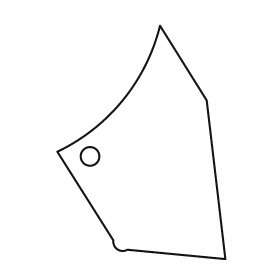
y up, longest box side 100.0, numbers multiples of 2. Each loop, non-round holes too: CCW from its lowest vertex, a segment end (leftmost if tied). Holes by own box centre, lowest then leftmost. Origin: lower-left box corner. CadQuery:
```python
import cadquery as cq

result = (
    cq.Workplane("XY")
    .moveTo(72.0, 0.0)
    .lineTo(64.0, 68.0)
    .lineTo(44.0, 100.0)
    .threePointArc((28.0, 68.0), (0.0, 46.0))
    .lineTo(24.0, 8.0)
    .threePointArc((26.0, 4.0), (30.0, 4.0))
    .close()
    .moveTo(14.0, 44.0)
    .circle(4.0)
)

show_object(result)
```